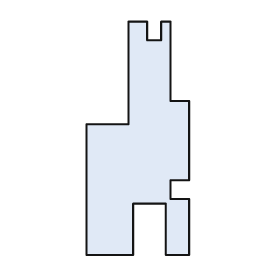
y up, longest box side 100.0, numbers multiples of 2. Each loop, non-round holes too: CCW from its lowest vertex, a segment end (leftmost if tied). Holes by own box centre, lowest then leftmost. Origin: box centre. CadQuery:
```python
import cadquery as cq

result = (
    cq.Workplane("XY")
    .moveTo(-22.0, -50.0)
    .lineTo(-2.0, -50.0)
    .lineTo(-2.0, -28.0)
    .lineTo(12.0, -28.0)
    .lineTo(12.0, -50.0)
    .lineTo(22.0, -50.0)
    .lineTo(22.0, -26.0)
    .lineTo(14.0, -26.0)
    .lineTo(14.0, -18.0)
    .lineTo(22.0, -18.0)
    .lineTo(22.0, 16.0)
    .lineTo(14.0, 16.0)
    .lineTo(14.0, 50.0)
    .lineTo(10.0, 50.0)
    .lineTo(10.0, 42.0)
    .lineTo(4.0, 42.0)
    .lineTo(4.0, 50.0)
    .lineTo(-4.0, 50.0)
    .lineTo(-4.0, 6.0)
    .lineTo(-22.0, 6.0)
    .close()
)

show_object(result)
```